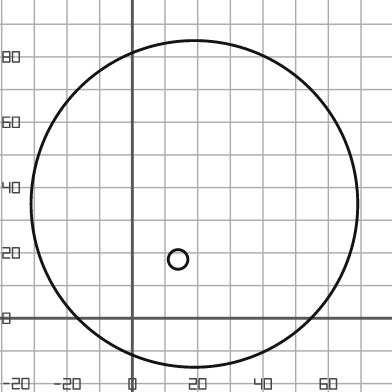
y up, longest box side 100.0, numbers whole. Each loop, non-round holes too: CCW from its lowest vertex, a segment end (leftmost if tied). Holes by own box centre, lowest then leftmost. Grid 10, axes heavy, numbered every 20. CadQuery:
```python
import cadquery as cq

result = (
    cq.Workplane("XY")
    .moveTo(19.0, 35.0)
    .circle(50.0)
    .moveTo(14.0, 18.0)
    .circle(3.0)
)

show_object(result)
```